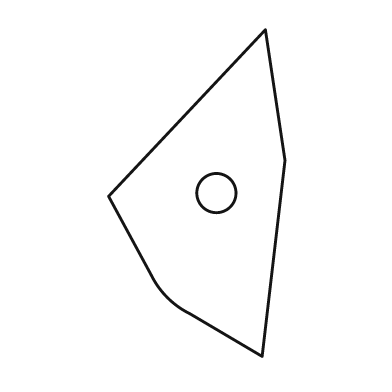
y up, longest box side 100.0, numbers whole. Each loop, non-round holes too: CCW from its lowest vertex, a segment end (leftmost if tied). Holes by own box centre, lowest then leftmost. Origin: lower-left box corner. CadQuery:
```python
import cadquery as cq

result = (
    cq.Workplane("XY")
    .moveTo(47.0, 0.0)
    .lineTo(54.0, 60.0)
    .lineTo(48.0, 100.0)
    .lineTo(0.0, 49.0)
    .lineTo(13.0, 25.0)
    .threePointArc((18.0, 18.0), (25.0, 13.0))
    .close()
    .moveTo(33.0, 50.0)
    .circle(6.0)
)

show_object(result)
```